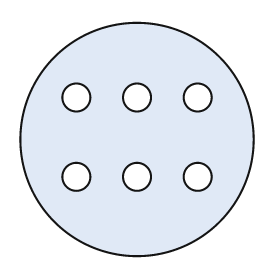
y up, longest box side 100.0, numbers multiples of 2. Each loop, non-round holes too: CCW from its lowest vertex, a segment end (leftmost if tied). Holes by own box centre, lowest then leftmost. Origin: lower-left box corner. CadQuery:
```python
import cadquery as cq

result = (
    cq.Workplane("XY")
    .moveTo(50.0, 50.0)
    .circle(50.0)
    .moveTo(24.0, 34.0)
    .circle(6.0)
    .moveTo(50.0, 34.0)
    .circle(6.0)
    .moveTo(76.0, 34.0)
    .circle(6.0)
    .moveTo(24.0, 68.0)
    .circle(6.0)
    .moveTo(50.0, 68.0)
    .circle(6.0)
    .moveTo(76.0, 68.0)
    .circle(6.0)
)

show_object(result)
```